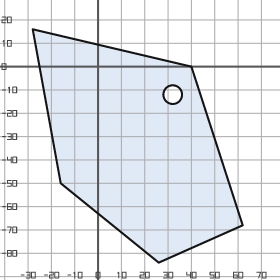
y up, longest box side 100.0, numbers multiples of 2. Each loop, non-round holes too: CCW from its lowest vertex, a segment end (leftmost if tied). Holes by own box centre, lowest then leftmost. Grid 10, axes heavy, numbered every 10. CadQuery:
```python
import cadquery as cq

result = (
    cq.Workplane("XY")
    .moveTo(26.0, -84.0)
    .lineTo(62.0, -68.0)
    .lineTo(40.0, 0.0)
    .lineTo(-28.0, 16.0)
    .lineTo(-16.0, -50.0)
    .close()
    .moveTo(32.0, -12.0)
    .circle(4.0)
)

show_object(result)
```